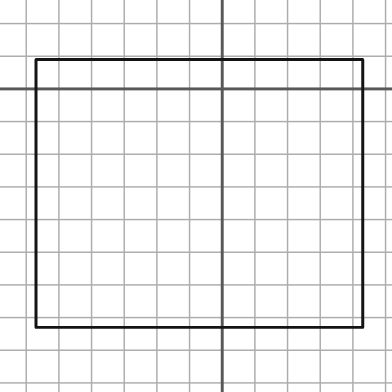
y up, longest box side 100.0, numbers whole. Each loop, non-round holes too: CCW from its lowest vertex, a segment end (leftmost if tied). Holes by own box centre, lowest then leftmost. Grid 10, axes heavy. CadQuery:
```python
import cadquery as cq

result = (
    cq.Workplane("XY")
    .moveTo(-57.0, -73.0)
    .lineTo(43.0, -73.0)
    .lineTo(43.0, 9.0)
    .lineTo(-57.0, 9.0)
    .close()
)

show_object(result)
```